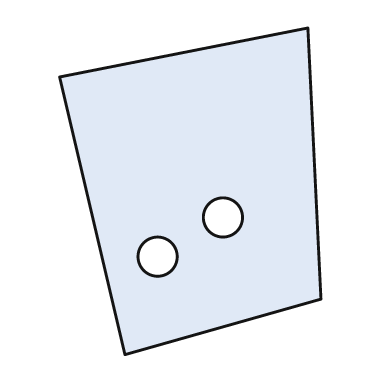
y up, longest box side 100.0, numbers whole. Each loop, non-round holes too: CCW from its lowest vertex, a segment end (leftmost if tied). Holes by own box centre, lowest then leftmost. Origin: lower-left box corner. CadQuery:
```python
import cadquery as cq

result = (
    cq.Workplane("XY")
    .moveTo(20.0, 0.0)
    .lineTo(80.0, 17.0)
    .lineTo(76.0, 100.0)
    .lineTo(0.0, 85.0)
    .close()
    .moveTo(30.0, 30.0)
    .circle(6.0)
    .moveTo(50.0, 42.0)
    .circle(6.0)
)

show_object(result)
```